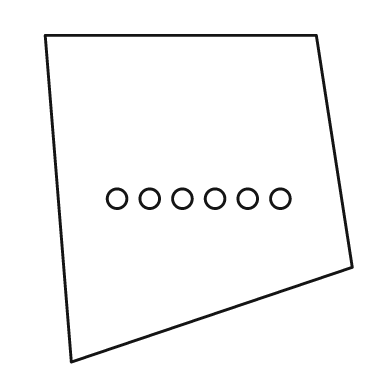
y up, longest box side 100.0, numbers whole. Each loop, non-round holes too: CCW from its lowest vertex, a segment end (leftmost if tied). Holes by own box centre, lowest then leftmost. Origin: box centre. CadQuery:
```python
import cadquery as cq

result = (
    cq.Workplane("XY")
    .moveTo(-39.0, -50.0)
    .lineTo(47.0, -21.0)
    .lineTo(36.0, 50.0)
    .lineTo(-47.0, 50.0)
    .close()
    .moveTo(-25.0, 0.0)
    .circle(3.0)
    .moveTo(-15.0, 0.0)
    .circle(3.0)
    .moveTo(-5.0, 0.0)
    .circle(3.0)
    .moveTo(5.0, 0.0)
    .circle(3.0)
    .moveTo(15.0, 0.0)
    .circle(3.0)
    .moveTo(25.0, 0.0)
    .circle(3.0)
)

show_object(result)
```